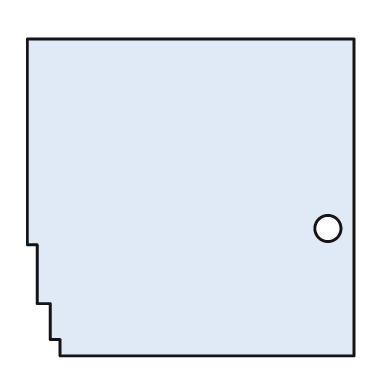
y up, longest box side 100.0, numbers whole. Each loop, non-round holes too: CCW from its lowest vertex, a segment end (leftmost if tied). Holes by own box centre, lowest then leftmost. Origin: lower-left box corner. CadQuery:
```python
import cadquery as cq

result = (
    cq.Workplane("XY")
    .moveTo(10.0, 0.0)
    .lineTo(100.0, 0.0)
    .lineTo(100.0, 97.0)
    .lineTo(0.0, 97.0)
    .lineTo(0.0, 34.0)
    .lineTo(3.0, 34.0)
    .lineTo(3.0, 16.0)
    .lineTo(7.0, 16.0)
    .lineTo(7.0, 5.0)
    .lineTo(10.0, 5.0)
    .close()
    .moveTo(92.0, 39.0)
    .circle(4.0)
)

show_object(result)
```